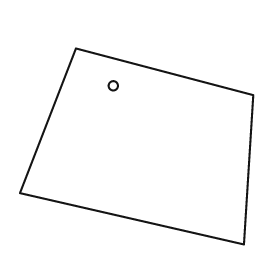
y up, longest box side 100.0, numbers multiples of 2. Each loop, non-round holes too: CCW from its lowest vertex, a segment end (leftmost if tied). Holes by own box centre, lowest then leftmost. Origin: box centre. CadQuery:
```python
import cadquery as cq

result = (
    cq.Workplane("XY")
    .moveTo(46.0, -42.0)
    .lineTo(50.0, 22.0)
    .lineTo(-26.0, 42.0)
    .lineTo(-50.0, -20.0)
    .close()
    .moveTo(-10.0, 26.0)
    .circle(2.0)
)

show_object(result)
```